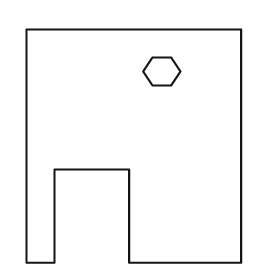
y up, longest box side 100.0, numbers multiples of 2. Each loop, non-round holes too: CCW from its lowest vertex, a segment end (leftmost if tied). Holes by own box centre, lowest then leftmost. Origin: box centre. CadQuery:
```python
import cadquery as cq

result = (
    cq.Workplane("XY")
    .moveTo(-46.0, -50.0)
    .lineTo(-34.0, -50.0)
    .lineTo(-34.0, -10.0)
    .lineTo(-2.0, -10.0)
    .lineTo(-2.0, -50.0)
    .lineTo(46.0, -50.0)
    .lineTo(46.0, 50.0)
    .lineTo(-46.0, 50.0)
    .close()
    .moveTo(8.0, 26.0)
    .lineTo(16.0, 26.0)
    .lineTo(20.0, 32.0)
    .lineTo(16.0, 38.0)
    .lineTo(8.0, 38.0)
    .lineTo(4.0, 32.0)
    .close()
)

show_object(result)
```